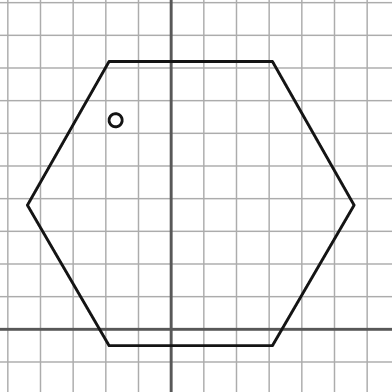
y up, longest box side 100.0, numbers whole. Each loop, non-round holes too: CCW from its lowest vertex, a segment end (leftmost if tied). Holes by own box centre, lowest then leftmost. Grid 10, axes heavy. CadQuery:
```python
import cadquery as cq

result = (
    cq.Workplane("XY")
    .moveTo(-19.0, -5.0)
    .lineTo(31.0, -5.0)
    .lineTo(56.0, 38.0)
    .lineTo(31.0, 82.0)
    .lineTo(-19.0, 82.0)
    .lineTo(-44.0, 38.0)
    .close()
    .moveTo(-17.0, 64.0)
    .circle(2.0)
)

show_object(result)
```